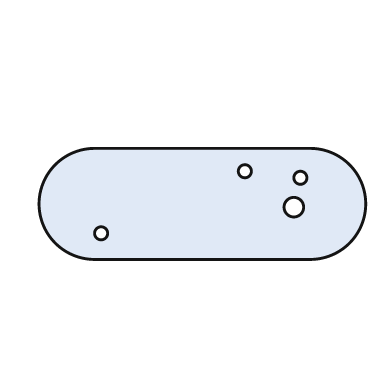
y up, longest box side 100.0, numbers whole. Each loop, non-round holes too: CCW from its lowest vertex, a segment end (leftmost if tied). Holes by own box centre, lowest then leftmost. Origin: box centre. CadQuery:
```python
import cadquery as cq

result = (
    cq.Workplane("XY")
    .moveTo(-33.0, -17.0)
    .lineTo(33.0, -17.0)
    .threePointArc((50.0, 0.0), (33.0, 17.0))
    .lineTo(-33.0, 17.0)
    .threePointArc((-50.0, 0.0), (-33.0, -17.0))
    .close()
    .moveTo(-31.0, -9.0)
    .circle(2.0)
    .moveTo(28.0, -1.0)
    .circle(3.0)
    .moveTo(30.0, 8.0)
    .circle(2.0)
    .moveTo(13.0, 10.0)
    .circle(2.0)
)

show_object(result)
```